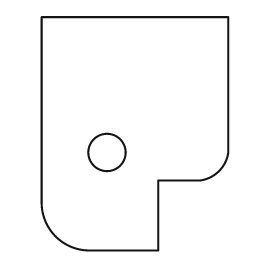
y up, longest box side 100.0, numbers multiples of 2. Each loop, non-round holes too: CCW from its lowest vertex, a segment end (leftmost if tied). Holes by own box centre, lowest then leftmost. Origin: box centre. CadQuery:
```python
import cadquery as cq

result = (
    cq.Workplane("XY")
    .moveTo(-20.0, -50.0)
    .lineTo(10.0, -50.0)
    .lineTo(10.0, -20.0)
    .lineTo(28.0, -20.0)
    .threePointArc((36.0, -16.0), (40.0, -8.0))
    .lineTo(40.0, 50.0)
    .lineTo(-40.0, 50.0)
    .lineTo(-40.0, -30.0)
    .threePointArc((-34.0, -44.0), (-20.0, -50.0))
    .close()
    .moveTo(-12.0, -8.0)
    .circle(8.0)
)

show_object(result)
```